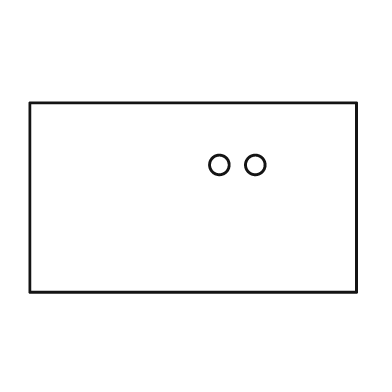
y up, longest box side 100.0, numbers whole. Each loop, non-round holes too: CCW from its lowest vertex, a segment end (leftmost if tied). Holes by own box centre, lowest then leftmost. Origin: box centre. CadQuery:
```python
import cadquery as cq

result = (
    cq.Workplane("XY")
    .moveTo(-50.0, -29.0)
    .lineTo(50.0, -29.0)
    .lineTo(50.0, 29.0)
    .lineTo(-50.0, 29.0)
    .close()
    .moveTo(8.0, 10.0)
    .circle(3.0)
    .moveTo(19.0, 10.0)
    .circle(3.0)
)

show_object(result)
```